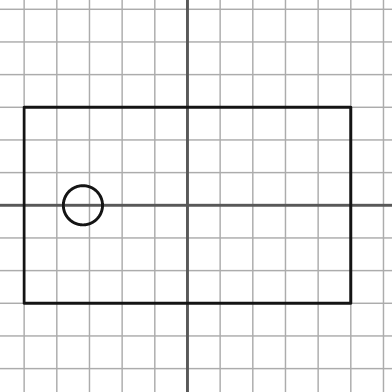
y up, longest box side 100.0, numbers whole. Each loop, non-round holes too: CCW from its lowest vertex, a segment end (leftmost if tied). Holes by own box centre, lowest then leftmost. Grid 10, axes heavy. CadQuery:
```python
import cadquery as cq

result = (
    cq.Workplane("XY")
    .moveTo(-50.0, -30.0)
    .lineTo(50.0, -30.0)
    .lineTo(50.0, 30.0)
    .lineTo(-50.0, 30.0)
    .close()
    .moveTo(-32.0, 0.0)
    .circle(6.0)
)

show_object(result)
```